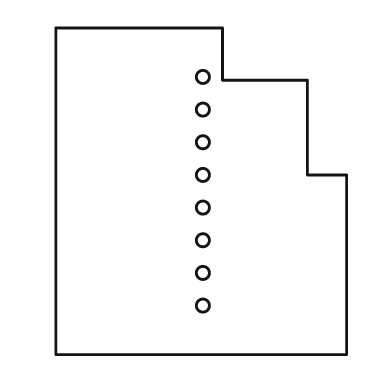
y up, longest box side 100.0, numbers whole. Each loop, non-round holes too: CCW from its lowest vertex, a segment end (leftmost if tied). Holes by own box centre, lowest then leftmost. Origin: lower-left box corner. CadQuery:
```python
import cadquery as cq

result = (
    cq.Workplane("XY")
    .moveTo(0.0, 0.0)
    .lineTo(89.0, 0.0)
    .lineTo(89.0, 55.0)
    .lineTo(77.0, 55.0)
    .lineTo(77.0, 84.0)
    .lineTo(51.0, 84.0)
    .lineTo(51.0, 100.0)
    .lineTo(0.0, 100.0)
    .close()
    .moveTo(45.0, 15.0)
    .circle(2.0)
    .moveTo(45.0, 25.0)
    .circle(2.0)
    .moveTo(45.0, 35.0)
    .circle(2.0)
    .moveTo(45.0, 45.0)
    .circle(2.0)
    .moveTo(45.0, 55.0)
    .circle(2.0)
    .moveTo(45.0, 65.0)
    .circle(2.0)
    .moveTo(45.0, 75.0)
    .circle(2.0)
    .moveTo(45.0, 85.0)
    .circle(2.0)
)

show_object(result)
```